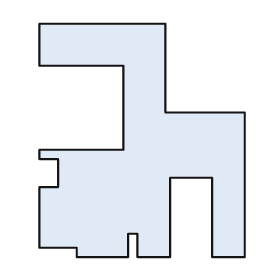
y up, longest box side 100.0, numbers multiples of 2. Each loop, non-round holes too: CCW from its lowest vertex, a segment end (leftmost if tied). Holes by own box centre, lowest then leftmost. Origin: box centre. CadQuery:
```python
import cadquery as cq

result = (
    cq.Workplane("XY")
    .moveTo(-28.0, -50.0)
    .lineTo(-6.0, -50.0)
    .lineTo(-6.0, -40.0)
    .lineTo(-2.0, -40.0)
    .lineTo(-2.0, -50.0)
    .lineTo(12.0, -50.0)
    .lineTo(12.0, -16.0)
    .lineTo(30.0, -16.0)
    .lineTo(30.0, -50.0)
    .lineTo(44.0, -50.0)
    .lineTo(44.0, 12.0)
    .lineTo(10.0, 12.0)
    .lineTo(10.0, 50.0)
    .lineTo(-44.0, 50.0)
    .lineTo(-44.0, 32.0)
    .lineTo(-8.0, 32.0)
    .lineTo(-8.0, -4.0)
    .lineTo(-44.0, -4.0)
    .lineTo(-44.0, -8.0)
    .lineTo(-36.0, -8.0)
    .lineTo(-36.0, -20.0)
    .lineTo(-44.0, -20.0)
    .lineTo(-44.0, -46.0)
    .lineTo(-28.0, -46.0)
    .close()
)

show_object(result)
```